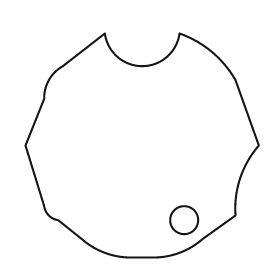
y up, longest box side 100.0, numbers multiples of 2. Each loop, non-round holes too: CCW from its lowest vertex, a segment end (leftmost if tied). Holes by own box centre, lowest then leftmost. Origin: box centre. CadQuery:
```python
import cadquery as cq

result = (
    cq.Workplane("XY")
    .moveTo(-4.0, -48.0)
    .lineTo(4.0, -48.0)
    .threePointArc((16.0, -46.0), (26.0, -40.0))
    .lineTo(40.0, -30.0)
    .threePointArc((42.0, -14.0), (50.0, 0.0))
    .lineTo(40.0, 28.0)
    .threePointArc((30.0, 40.0), (16.0, 48.0))
    .threePointArc((0.0, 34.0), (-16.0, 48.0))
    .lineTo(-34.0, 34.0)
    .threePointArc((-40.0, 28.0), (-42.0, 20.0))
    .lineTo(-50.0, 0.0)
    .lineTo(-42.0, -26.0)
    .threePointArc((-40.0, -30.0), (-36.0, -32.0))
    .lineTo(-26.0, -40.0)
    .threePointArc((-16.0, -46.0), (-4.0, -48.0))
    .close()
    .moveTo(18.0, -32.0)
    .circle(6.0)
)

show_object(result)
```